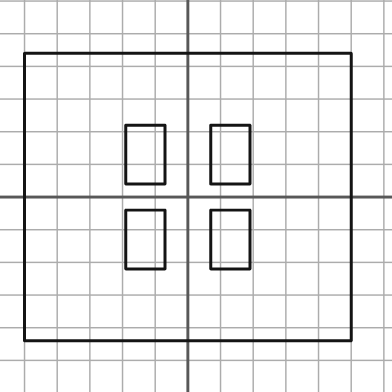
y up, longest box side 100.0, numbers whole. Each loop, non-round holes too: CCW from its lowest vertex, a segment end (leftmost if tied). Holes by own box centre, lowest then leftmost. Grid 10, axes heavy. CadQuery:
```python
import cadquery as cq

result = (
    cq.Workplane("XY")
    .moveTo(-50.0, -44.0)
    .lineTo(50.0, -44.0)
    .lineTo(50.0, 44.0)
    .lineTo(-50.0, 44.0)
    .close()
    .moveTo(-19.0, -22.0)
    .lineTo(-7.0, -22.0)
    .lineTo(-7.0, -4.0)
    .lineTo(-19.0, -4.0)
    .close()
    .moveTo(7.0, -22.0)
    .lineTo(19.0, -22.0)
    .lineTo(19.0, -4.0)
    .lineTo(7.0, -4.0)
    .close()
    .moveTo(-19.0, 4.0)
    .lineTo(-7.0, 4.0)
    .lineTo(-7.0, 22.0)
    .lineTo(-19.0, 22.0)
    .close()
    .moveTo(7.0, 4.0)
    .lineTo(19.0, 4.0)
    .lineTo(19.0, 22.0)
    .lineTo(7.0, 22.0)
    .close()
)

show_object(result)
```